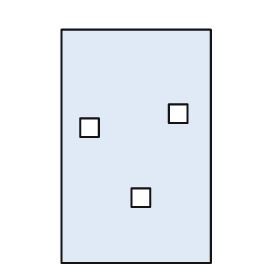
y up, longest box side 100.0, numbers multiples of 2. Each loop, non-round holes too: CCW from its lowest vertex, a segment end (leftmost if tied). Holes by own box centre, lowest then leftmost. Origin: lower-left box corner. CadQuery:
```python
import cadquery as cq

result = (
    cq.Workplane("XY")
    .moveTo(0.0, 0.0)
    .lineTo(64.0, 0.0)
    .lineTo(64.0, 100.0)
    .lineTo(0.0, 100.0)
    .close()
    .moveTo(30.0, 24.0)
    .lineTo(38.0, 24.0)
    .lineTo(38.0, 32.0)
    .lineTo(30.0, 32.0)
    .close()
    .moveTo(8.0, 54.0)
    .lineTo(16.0, 54.0)
    .lineTo(16.0, 62.0)
    .lineTo(8.0, 62.0)
    .close()
    .moveTo(46.0, 60.0)
    .lineTo(54.0, 60.0)
    .lineTo(54.0, 68.0)
    .lineTo(46.0, 68.0)
    .close()
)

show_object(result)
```